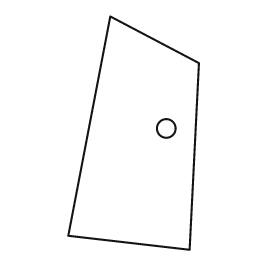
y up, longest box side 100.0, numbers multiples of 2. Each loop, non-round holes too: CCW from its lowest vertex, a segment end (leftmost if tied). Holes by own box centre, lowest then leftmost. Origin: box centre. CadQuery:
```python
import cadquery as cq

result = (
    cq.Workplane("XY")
    .moveTo(24.0, -50.0)
    .lineTo(28.0, 30.0)
    .lineTo(-10.0, 50.0)
    .lineTo(-28.0, -44.0)
    .close()
    .moveTo(14.0, 2.0)
    .circle(4.0)
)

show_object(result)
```